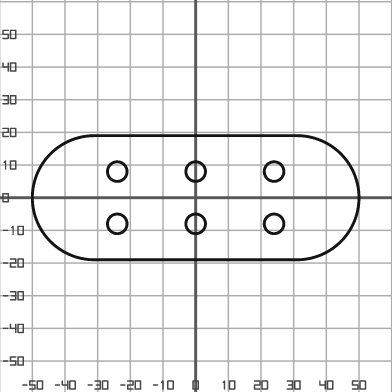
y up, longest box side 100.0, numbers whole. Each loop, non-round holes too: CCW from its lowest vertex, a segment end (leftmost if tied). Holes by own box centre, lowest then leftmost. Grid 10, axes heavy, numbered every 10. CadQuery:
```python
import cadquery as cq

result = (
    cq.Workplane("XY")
    .moveTo(-31.0, -19.0)
    .lineTo(31.0, -19.0)
    .threePointArc((50.0, 0.0), (31.0, 19.0))
    .lineTo(-31.0, 19.0)
    .threePointArc((-50.0, 0.0), (-31.0, -19.0))
    .close()
    .moveTo(-24.0, -8.0)
    .circle(3.0)
    .moveTo(0.0, -8.0)
    .circle(3.0)
    .moveTo(24.0, -8.0)
    .circle(3.0)
    .moveTo(-24.0, 8.0)
    .circle(3.0)
    .moveTo(0.0, 8.0)
    .circle(3.0)
    .moveTo(24.0, 8.0)
    .circle(3.0)
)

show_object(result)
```